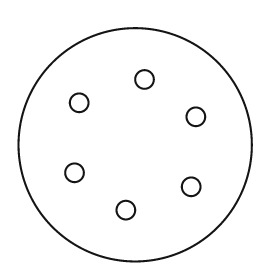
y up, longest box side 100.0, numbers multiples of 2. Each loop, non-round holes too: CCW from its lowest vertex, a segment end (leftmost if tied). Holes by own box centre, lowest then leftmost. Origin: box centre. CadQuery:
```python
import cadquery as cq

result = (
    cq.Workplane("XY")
    .moveTo(0.0, 0.0)
    .circle(50.0)
    .moveTo(-4.0, -28.0)
    .circle(4.0)
    .moveTo(24.0, -18.0)
    .circle(4.0)
    .moveTo(-26.0, -12.0)
    .circle(4.0)
    .moveTo(26.0, 12.0)
    .circle(4.0)
    .moveTo(-24.0, 18.0)
    .circle(4.0)
    .moveTo(4.0, 28.0)
    .circle(4.0)
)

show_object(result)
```